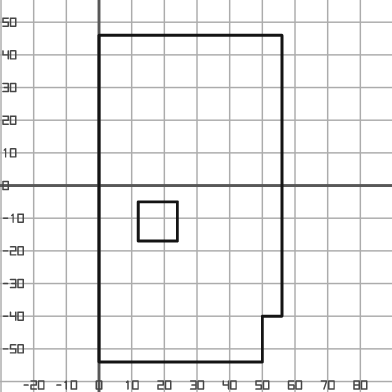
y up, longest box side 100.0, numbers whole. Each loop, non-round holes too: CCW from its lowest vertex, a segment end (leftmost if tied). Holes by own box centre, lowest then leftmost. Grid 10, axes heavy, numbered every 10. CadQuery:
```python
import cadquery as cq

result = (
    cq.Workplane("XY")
    .moveTo(0.0, -54.0)
    .lineTo(50.0, -54.0)
    .lineTo(50.0, -40.0)
    .lineTo(56.0, -40.0)
    .lineTo(56.0, 46.0)
    .lineTo(0.0, 46.0)
    .close()
    .moveTo(12.0, -17.0)
    .lineTo(24.0, -17.0)
    .lineTo(24.0, -5.0)
    .lineTo(12.0, -5.0)
    .close()
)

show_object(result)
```